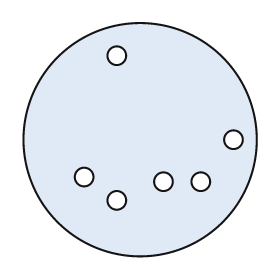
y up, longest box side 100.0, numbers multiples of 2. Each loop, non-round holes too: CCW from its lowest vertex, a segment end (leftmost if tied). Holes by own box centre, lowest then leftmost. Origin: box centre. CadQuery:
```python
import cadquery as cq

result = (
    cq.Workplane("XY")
    .moveTo(0.0, 0.0)
    .circle(50.0)
    .moveTo(-10.0, -26.0)
    .circle(4.0)
    .moveTo(10.0, -18.0)
    .circle(4.0)
    .moveTo(26.0, -18.0)
    .circle(4.0)
    .moveTo(-24.0, -16.0)
    .circle(4.0)
    .moveTo(40.0, 0.0)
    .circle(4.0)
    .moveTo(-10.0, 36.0)
    .circle(4.0)
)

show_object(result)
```